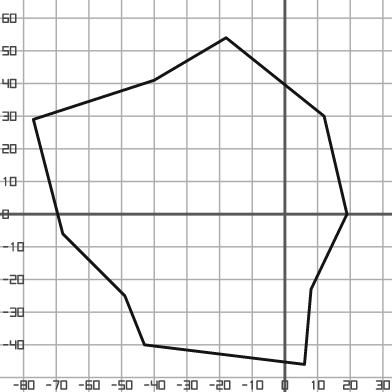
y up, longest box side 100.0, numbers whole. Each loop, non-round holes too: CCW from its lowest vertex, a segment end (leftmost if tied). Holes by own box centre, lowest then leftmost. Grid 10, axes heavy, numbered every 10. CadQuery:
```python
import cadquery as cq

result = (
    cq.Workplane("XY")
    .moveTo(6.0, -46.0)
    .lineTo(8.0, -23.0)
    .lineTo(19.0, 0.0)
    .lineTo(12.0, 30.0)
    .lineTo(-18.0, 54.0)
    .lineTo(-40.0, 41.0)
    .lineTo(-77.0, 29.0)
    .lineTo(-68.0, -6.0)
    .lineTo(-49.0, -25.0)
    .lineTo(-43.0, -40.0)
    .close()
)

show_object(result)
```